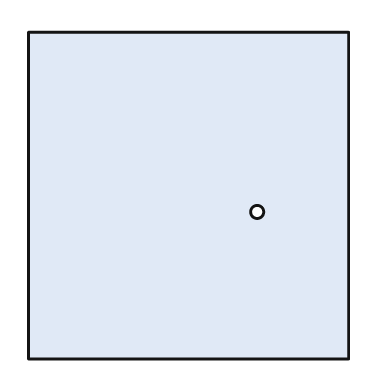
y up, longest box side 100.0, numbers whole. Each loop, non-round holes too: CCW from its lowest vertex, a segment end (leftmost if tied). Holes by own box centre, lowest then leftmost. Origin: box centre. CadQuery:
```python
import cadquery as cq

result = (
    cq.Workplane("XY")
    .moveTo(-49.0, -50.0)
    .lineTo(49.0, -50.0)
    .lineTo(49.0, 50.0)
    .lineTo(-49.0, 50.0)
    .close()
    .moveTo(21.0, -5.0)
    .circle(2.0)
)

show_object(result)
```